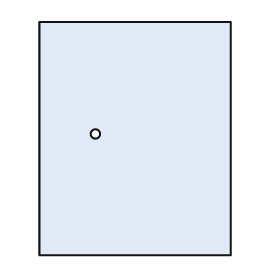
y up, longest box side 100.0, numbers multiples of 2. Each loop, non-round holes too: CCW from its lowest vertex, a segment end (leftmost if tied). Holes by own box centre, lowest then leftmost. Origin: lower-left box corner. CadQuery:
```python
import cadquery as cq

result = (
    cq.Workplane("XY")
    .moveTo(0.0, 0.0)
    .lineTo(82.0, 0.0)
    .lineTo(82.0, 100.0)
    .lineTo(0.0, 100.0)
    .close()
    .moveTo(24.0, 52.0)
    .circle(2.0)
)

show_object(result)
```